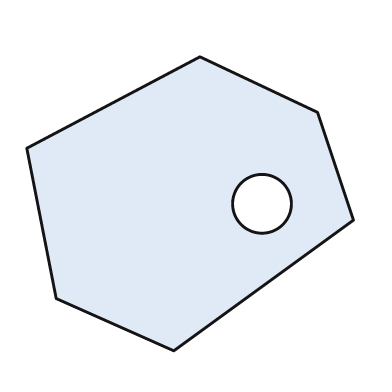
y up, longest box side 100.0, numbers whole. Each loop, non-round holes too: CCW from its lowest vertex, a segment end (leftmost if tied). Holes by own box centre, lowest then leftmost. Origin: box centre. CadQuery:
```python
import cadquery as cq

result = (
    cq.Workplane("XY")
    .moveTo(-5.0, -45.0)
    .lineTo(50.0, -5.0)
    .lineTo(39.0, 28.0)
    .lineTo(3.0, 45.0)
    .lineTo(-50.0, 17.0)
    .lineTo(-41.0, -29.0)
    .close()
    .moveTo(22.0, 0.0)
    .circle(9.0)
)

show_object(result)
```